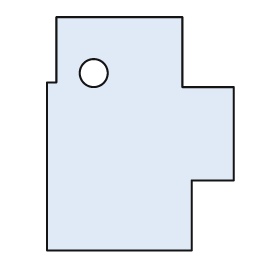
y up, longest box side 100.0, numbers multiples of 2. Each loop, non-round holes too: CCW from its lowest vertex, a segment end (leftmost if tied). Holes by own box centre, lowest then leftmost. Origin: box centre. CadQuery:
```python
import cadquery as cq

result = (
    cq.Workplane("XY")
    .moveTo(-40.0, -50.0)
    .lineTo(22.0, -50.0)
    .lineTo(22.0, -20.0)
    .lineTo(40.0, -20.0)
    .lineTo(40.0, 20.0)
    .lineTo(18.0, 20.0)
    .lineTo(18.0, 50.0)
    .lineTo(-36.0, 50.0)
    .lineTo(-36.0, 22.0)
    .lineTo(-40.0, 22.0)
    .close()
    .moveTo(-20.0, 26.0)
    .circle(6.0)
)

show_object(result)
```